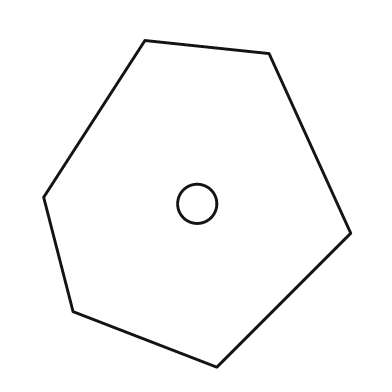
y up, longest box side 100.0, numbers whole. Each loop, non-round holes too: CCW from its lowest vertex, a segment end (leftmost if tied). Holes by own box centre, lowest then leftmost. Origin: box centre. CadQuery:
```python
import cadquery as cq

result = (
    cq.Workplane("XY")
    .moveTo(6.0, -50.0)
    .lineTo(47.0, -9.0)
    .lineTo(22.0, 46.0)
    .lineTo(-16.0, 50.0)
    .lineTo(-47.0, 2.0)
    .lineTo(-38.0, -33.0)
    .close()
    .moveTo(0.0, 0.0)
    .circle(6.0)
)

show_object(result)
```